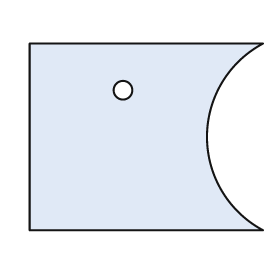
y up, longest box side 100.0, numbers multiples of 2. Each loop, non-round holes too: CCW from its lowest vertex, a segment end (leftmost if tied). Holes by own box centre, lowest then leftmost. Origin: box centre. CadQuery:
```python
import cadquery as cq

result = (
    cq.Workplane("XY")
    .moveTo(-50.0, -40.0)
    .lineTo(50.0, -40.0)
    .threePointArc((26.0, 0.0), (50.0, 40.0))
    .lineTo(-50.0, 40.0)
    .close()
    .moveTo(-10.0, 20.0)
    .circle(4.0)
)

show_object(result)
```